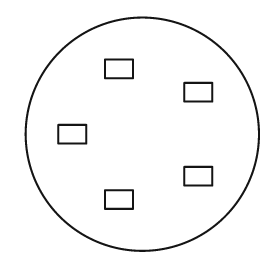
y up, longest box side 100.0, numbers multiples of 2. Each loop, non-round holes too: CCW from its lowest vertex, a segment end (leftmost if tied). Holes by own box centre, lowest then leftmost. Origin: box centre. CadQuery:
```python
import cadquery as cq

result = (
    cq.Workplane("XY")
    .moveTo(0.0, 0.0)
    .circle(50.0)
    .moveTo(-16.0, -32.0)
    .lineTo(-4.0, -32.0)
    .lineTo(-4.0, -24.0)
    .lineTo(-16.0, -24.0)
    .close()
    .moveTo(18.0, -22.0)
    .lineTo(30.0, -22.0)
    .lineTo(30.0, -14.0)
    .lineTo(18.0, -14.0)
    .close()
    .moveTo(-36.0, -4.0)
    .lineTo(-24.0, -4.0)
    .lineTo(-24.0, 4.0)
    .lineTo(-36.0, 4.0)
    .close()
    .moveTo(18.0, 14.0)
    .lineTo(30.0, 14.0)
    .lineTo(30.0, 22.0)
    .lineTo(18.0, 22.0)
    .close()
    .moveTo(-16.0, 24.0)
    .lineTo(-4.0, 24.0)
    .lineTo(-4.0, 32.0)
    .lineTo(-16.0, 32.0)
    .close()
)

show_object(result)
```